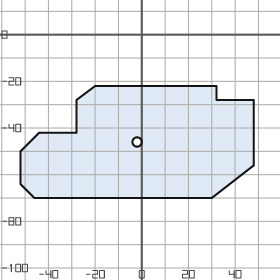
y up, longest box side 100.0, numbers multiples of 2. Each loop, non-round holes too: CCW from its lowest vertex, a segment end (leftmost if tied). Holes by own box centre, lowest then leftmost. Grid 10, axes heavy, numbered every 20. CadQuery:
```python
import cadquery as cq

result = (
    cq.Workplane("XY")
    .moveTo(-46.0, -70.0)
    .lineTo(30.0, -70.0)
    .lineTo(48.0, -56.0)
    .lineTo(48.0, -28.0)
    .lineTo(32.0, -28.0)
    .lineTo(32.0, -22.0)
    .lineTo(-20.0, -22.0)
    .lineTo(-28.0, -28.0)
    .lineTo(-28.0, -42.0)
    .lineTo(-44.0, -42.0)
    .lineTo(-52.0, -50.0)
    .lineTo(-52.0, -64.0)
    .close()
    .moveTo(-2.0, -46.0)
    .circle(2.0)
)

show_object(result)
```